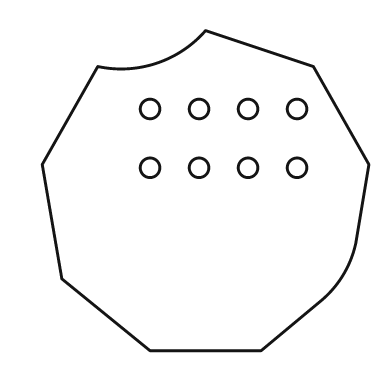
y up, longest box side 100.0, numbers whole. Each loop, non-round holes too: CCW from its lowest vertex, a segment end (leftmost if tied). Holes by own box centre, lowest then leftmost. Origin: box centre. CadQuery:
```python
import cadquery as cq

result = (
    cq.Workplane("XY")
    .moveTo(-17.0, -49.0)
    .lineTo(17.0, -49.0)
    .lineTo(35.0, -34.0)
    .threePointArc((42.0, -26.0), (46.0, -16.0))
    .lineTo(50.0, 8.0)
    .lineTo(33.0, 38.0)
    .lineTo(0.0, 49.0)
    .threePointArc((-15.0, 39.0), (-33.0, 38.0))
    .lineTo(-50.0, 8.0)
    .lineTo(-44.0, -27.0)
    .close()
    .moveTo(-17.0, 7.0)
    .circle(3.0)
    .moveTo(-2.0, 7.0)
    .circle(3.0)
    .moveTo(13.0, 7.0)
    .circle(3.0)
    .moveTo(28.0, 7.0)
    .circle(3.0)
    .moveTo(-17.0, 25.0)
    .circle(3.0)
    .moveTo(-2.0, 25.0)
    .circle(3.0)
    .moveTo(13.0, 25.0)
    .circle(3.0)
    .moveTo(28.0, 25.0)
    .circle(3.0)
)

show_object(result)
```